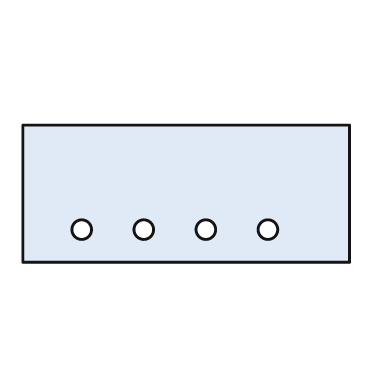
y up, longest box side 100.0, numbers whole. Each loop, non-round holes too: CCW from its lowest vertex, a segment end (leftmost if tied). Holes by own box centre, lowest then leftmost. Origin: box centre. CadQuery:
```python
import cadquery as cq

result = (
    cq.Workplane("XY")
    .moveTo(-50.0, -21.0)
    .lineTo(50.0, -21.0)
    .lineTo(50.0, 21.0)
    .lineTo(-50.0, 21.0)
    .close()
    .moveTo(-32.0, -11.0)
    .circle(3.0)
    .moveTo(-13.0, -11.0)
    .circle(3.0)
    .moveTo(6.0, -11.0)
    .circle(3.0)
    .moveTo(25.0, -11.0)
    .circle(3.0)
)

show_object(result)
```